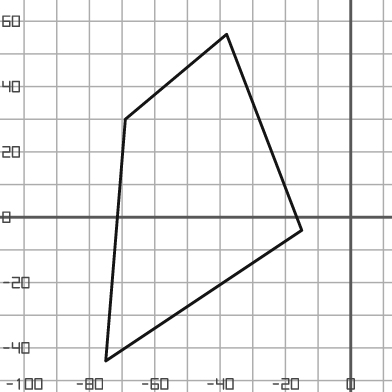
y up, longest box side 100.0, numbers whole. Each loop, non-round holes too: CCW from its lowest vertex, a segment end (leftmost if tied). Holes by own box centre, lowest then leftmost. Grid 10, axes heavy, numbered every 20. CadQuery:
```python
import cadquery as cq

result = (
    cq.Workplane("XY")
    .moveTo(-75.0, -44.0)
    .lineTo(-15.0, -4.0)
    .lineTo(-38.0, 56.0)
    .lineTo(-69.0, 30.0)
    .close()
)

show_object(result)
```